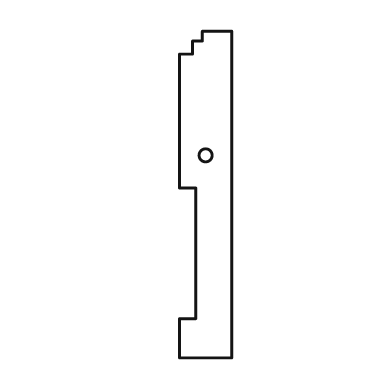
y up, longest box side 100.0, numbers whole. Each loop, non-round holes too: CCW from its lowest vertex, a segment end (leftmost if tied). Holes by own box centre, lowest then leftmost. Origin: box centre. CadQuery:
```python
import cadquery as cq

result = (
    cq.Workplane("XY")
    .moveTo(-8.0, -50.0)
    .lineTo(8.0, -50.0)
    .lineTo(8.0, 50.0)
    .lineTo(-1.0, 50.0)
    .lineTo(-1.0, 47.0)
    .lineTo(-4.0, 47.0)
    .lineTo(-4.0, 43.0)
    .lineTo(-8.0, 43.0)
    .lineTo(-8.0, 2.0)
    .lineTo(-3.0, 2.0)
    .lineTo(-3.0, -38.0)
    .lineTo(-8.0, -38.0)
    .close()
    .moveTo(0.0, 12.0)
    .circle(2.0)
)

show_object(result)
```